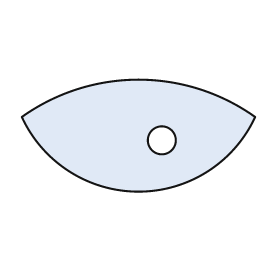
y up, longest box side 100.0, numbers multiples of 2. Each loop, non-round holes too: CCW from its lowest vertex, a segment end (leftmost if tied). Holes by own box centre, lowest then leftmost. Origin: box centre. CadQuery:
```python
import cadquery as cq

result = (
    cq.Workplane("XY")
    .moveTo(-50.0, 8.0)
    .threePointArc((0.0, -24.0), (50.0, 8.0))
    .threePointArc((0.0, 24.0), (-50.0, 8.0))
    .close()
    .moveTo(10.0, -2.0)
    .circle(6.0)
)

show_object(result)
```